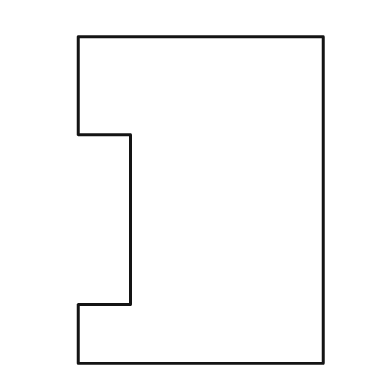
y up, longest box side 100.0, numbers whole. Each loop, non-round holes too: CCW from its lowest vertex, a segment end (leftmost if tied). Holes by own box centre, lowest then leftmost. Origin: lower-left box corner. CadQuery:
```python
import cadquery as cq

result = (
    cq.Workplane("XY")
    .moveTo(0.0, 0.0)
    .lineTo(75.0, 0.0)
    .lineTo(75.0, 100.0)
    .lineTo(0.0, 100.0)
    .lineTo(0.0, 70.0)
    .lineTo(16.0, 70.0)
    .lineTo(16.0, 18.0)
    .lineTo(0.0, 18.0)
    .close()
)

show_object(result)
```